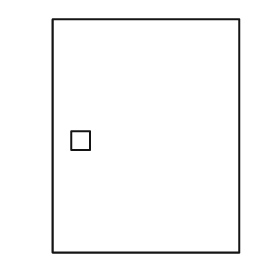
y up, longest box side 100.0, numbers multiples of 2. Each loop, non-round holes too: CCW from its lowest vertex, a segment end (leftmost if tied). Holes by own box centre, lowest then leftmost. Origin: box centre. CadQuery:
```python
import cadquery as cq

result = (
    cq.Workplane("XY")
    .moveTo(-40.0, -50.0)
    .lineTo(40.0, -50.0)
    .lineTo(40.0, 50.0)
    .lineTo(-40.0, 50.0)
    .close()
    .moveTo(-32.0, -6.0)
    .lineTo(-24.0, -6.0)
    .lineTo(-24.0, 2.0)
    .lineTo(-32.0, 2.0)
    .close()
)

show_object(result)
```